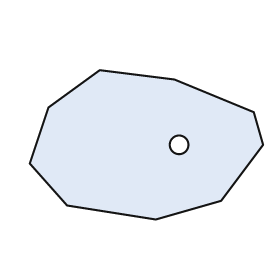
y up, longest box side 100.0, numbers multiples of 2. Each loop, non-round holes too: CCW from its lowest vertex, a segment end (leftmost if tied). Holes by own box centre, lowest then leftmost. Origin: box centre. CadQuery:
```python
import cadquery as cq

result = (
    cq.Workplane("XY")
    .moveTo(4.0, -32.0)
    .lineTo(32.0, -24.0)
    .lineTo(50.0, 0.0)
    .lineTo(46.0, 14.0)
    .lineTo(12.0, 28.0)
    .lineTo(-20.0, 32.0)
    .lineTo(-42.0, 16.0)
    .lineTo(-50.0, -8.0)
    .lineTo(-34.0, -26.0)
    .close()
    .moveTo(14.0, 0.0)
    .circle(4.0)
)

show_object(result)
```